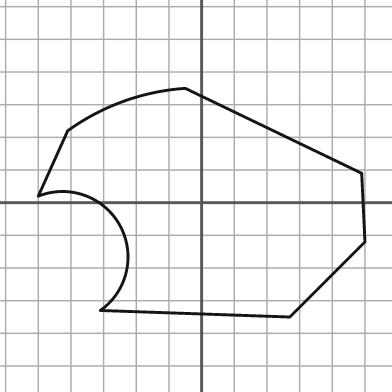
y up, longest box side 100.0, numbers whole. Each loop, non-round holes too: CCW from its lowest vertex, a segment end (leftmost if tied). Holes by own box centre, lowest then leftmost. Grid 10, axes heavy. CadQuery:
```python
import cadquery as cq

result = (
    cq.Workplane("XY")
    .moveTo(27.0, -35.0)
    .lineTo(50.0, -12.0)
    .lineTo(49.0, 9.0)
    .lineTo(-5.0, 35.0)
    .threePointArc((-24.0, 31.0), (-41.0, 22.0))
    .lineTo(-50.0, 2.0)
    .threePointArc((-25.0, -7.0), (-31.0, -33.0))
    .close()
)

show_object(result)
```